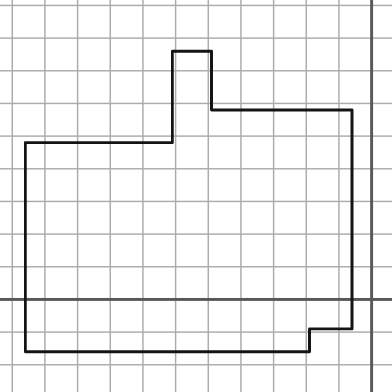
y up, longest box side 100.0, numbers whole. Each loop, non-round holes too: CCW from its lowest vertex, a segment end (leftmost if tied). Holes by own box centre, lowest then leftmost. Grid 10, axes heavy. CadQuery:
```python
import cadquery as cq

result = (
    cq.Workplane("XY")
    .moveTo(-106.0, -16.0)
    .lineTo(-19.0, -16.0)
    .lineTo(-19.0, -9.0)
    .lineTo(-6.0, -9.0)
    .lineTo(-6.0, 58.0)
    .lineTo(-49.0, 58.0)
    .lineTo(-49.0, 76.0)
    .lineTo(-61.0, 76.0)
    .lineTo(-61.0, 48.0)
    .lineTo(-106.0, 48.0)
    .close()
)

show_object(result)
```